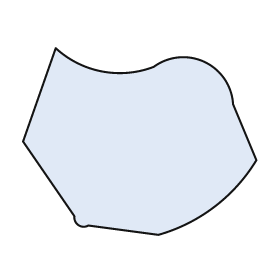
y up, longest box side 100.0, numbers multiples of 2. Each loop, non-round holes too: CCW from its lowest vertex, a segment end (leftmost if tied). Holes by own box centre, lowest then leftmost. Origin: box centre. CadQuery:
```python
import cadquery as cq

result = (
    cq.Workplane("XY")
    .moveTo(8.0, -40.0)
    .threePointArc((32.0, -28.0), (50.0, -8.0))
    .lineTo(40.0, 16.0)
    .threePointArc((28.0, 34.0), (6.0, 32.0))
    .threePointArc((-16.0, 30.0), (-36.0, 40.0))
    .lineTo(-50.0, 0.0)
    .lineTo(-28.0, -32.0)
    .threePointArc((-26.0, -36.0), (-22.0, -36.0))
    .close()
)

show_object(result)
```